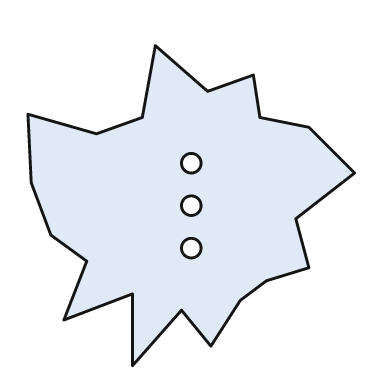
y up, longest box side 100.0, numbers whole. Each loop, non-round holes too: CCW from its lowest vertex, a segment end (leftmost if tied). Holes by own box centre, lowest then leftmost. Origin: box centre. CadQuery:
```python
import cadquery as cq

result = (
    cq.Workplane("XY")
    .moveTo(-18.0, -49.0)
    .lineTo(-3.0, -32.0)
    .lineTo(6.0, -43.0)
    .lineTo(15.0, -29.0)
    .lineTo(23.0, -23.0)
    .lineTo(36.0, -19.0)
    .lineTo(32.0, -4.0)
    .lineTo(50.0, 10.0)
    .lineTo(36.0, 24.0)
    .lineTo(21.0, 27.0)
    .lineTo(19.0, 40.0)
    .lineTo(5.0, 35.0)
    .lineTo(-11.0, 49.0)
    .lineTo(-15.0, 27.0)
    .lineTo(-29.0, 22.0)
    .lineTo(-50.0, 28.0)
    .lineTo(-49.0, 7.0)
    .lineTo(-43.0, -9.0)
    .lineTo(-32.0, -17.0)
    .lineTo(-39.0, -35.0)
    .lineTo(-18.0, -27.0)
    .close()
    .moveTo(0.0, -13.0)
    .circle(3.0)
    .moveTo(0.0, 0.0)
    .circle(3.0)
    .moveTo(0.0, 13.0)
    .circle(3.0)
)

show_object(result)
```